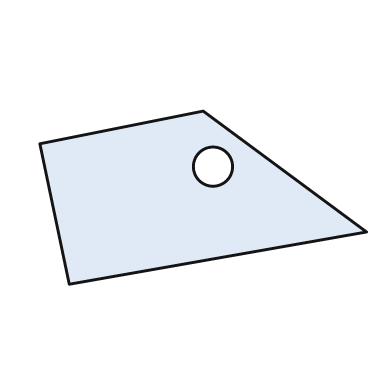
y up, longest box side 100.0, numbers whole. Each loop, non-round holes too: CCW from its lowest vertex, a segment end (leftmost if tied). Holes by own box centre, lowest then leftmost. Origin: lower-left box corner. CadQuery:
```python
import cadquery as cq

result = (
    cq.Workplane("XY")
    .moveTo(9.0, 0.0)
    .lineTo(100.0, 16.0)
    .lineTo(50.0, 53.0)
    .lineTo(0.0, 43.0)
    .close()
    .moveTo(53.0, 36.0)
    .circle(6.0)
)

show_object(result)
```